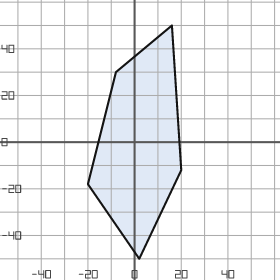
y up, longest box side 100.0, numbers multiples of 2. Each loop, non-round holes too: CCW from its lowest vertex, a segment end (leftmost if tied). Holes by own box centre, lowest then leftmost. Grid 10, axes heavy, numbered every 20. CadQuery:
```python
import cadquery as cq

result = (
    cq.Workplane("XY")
    .moveTo(2.0, -50.0)
    .lineTo(20.0, -12.0)
    .lineTo(16.0, 50.0)
    .lineTo(-8.0, 30.0)
    .lineTo(-20.0, -18.0)
    .close()
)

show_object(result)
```